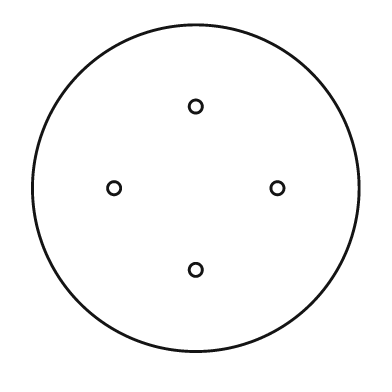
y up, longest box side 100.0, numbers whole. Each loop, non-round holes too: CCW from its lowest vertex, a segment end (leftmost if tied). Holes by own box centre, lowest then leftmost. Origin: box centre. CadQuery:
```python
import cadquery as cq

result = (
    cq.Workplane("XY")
    .moveTo(0.0, 0.0)
    .circle(50.0)
    .moveTo(0.0, -25.0)
    .circle(2.0)
    .moveTo(-25.0, 0.0)
    .circle(2.0)
    .moveTo(25.0, 0.0)
    .circle(2.0)
    .moveTo(0.0, 25.0)
    .circle(2.0)
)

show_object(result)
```